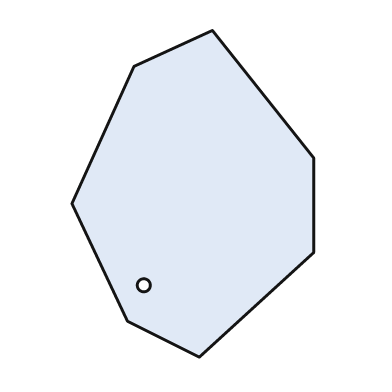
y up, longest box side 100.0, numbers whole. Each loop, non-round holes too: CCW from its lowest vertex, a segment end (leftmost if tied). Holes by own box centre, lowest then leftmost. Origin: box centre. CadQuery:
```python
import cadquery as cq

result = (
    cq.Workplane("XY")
    .moveTo(2.0, -50.0)
    .lineTo(37.0, -18.0)
    .lineTo(37.0, 11.0)
    .lineTo(6.0, 50.0)
    .lineTo(-18.0, 39.0)
    .lineTo(-37.0, -3.0)
    .lineTo(-20.0, -39.0)
    .close()
    .moveTo(-15.0, -28.0)
    .circle(2.0)
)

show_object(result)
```